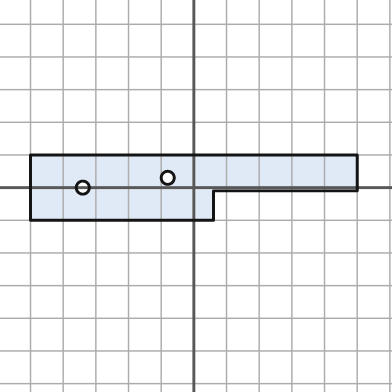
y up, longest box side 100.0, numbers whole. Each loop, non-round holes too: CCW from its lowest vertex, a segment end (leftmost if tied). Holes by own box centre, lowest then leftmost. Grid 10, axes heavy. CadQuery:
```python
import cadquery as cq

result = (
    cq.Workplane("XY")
    .moveTo(-50.0, -10.0)
    .lineTo(6.0, -10.0)
    .lineTo(6.0, -1.0)
    .lineTo(50.0, -1.0)
    .lineTo(50.0, 10.0)
    .lineTo(-50.0, 10.0)
    .close()
    .moveTo(-34.0, 0.0)
    .circle(2.0)
    .moveTo(-8.0, 3.0)
    .circle(2.0)
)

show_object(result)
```